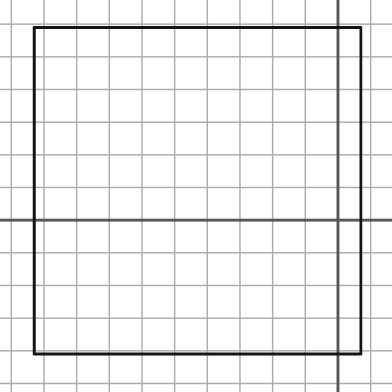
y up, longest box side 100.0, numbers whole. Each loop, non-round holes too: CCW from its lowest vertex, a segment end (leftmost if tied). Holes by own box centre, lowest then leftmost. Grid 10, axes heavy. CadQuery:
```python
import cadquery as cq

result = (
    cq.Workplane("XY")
    .moveTo(-93.0, -41.0)
    .lineTo(7.0, -41.0)
    .lineTo(7.0, 59.0)
    .lineTo(-93.0, 59.0)
    .close()
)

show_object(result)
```